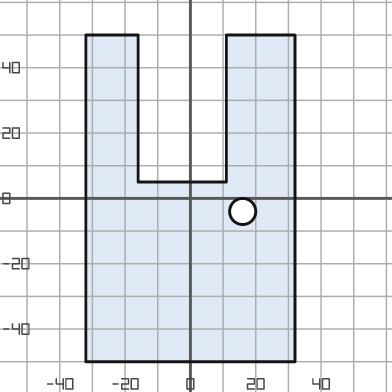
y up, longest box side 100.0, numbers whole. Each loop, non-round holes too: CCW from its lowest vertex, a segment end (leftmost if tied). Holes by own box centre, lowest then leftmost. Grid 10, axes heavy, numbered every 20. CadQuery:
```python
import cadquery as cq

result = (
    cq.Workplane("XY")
    .moveTo(-32.0, -50.0)
    .lineTo(32.0, -50.0)
    .lineTo(32.0, 50.0)
    .lineTo(11.0, 50.0)
    .lineTo(11.0, 5.0)
    .lineTo(-16.0, 5.0)
    .lineTo(-16.0, 50.0)
    .lineTo(-32.0, 50.0)
    .close()
    .moveTo(16.0, -4.0)
    .circle(4.0)
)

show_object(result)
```